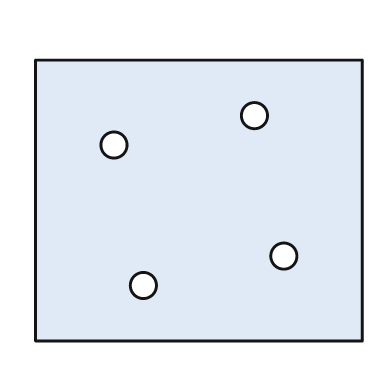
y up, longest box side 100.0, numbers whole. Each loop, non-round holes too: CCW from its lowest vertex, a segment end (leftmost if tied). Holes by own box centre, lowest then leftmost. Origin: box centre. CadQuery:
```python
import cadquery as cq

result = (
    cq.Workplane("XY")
    .moveTo(-50.0, -43.0)
    .lineTo(50.0, -43.0)
    .lineTo(50.0, 43.0)
    .lineTo(-50.0, 43.0)
    .close()
    .moveTo(-17.0, -26.0)
    .circle(4.0)
    .moveTo(26.0, -17.0)
    .circle(4.0)
    .moveTo(-26.0, 17.0)
    .circle(4.0)
    .moveTo(17.0, 26.0)
    .circle(4.0)
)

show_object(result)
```